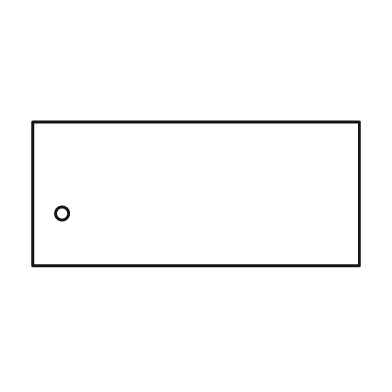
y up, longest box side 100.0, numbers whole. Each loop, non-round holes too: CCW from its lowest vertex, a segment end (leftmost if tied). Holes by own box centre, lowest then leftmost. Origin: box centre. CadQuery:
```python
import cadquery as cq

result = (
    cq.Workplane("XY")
    .moveTo(-50.0, -22.0)
    .lineTo(50.0, -22.0)
    .lineTo(50.0, 22.0)
    .lineTo(-50.0, 22.0)
    .close()
    .moveTo(-41.0, -6.0)
    .circle(2.0)
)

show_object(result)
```